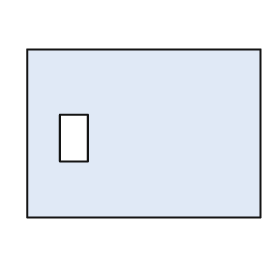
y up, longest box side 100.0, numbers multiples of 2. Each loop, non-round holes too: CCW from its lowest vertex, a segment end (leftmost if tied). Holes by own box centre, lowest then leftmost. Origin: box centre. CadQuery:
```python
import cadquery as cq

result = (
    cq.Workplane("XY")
    .moveTo(-50.0, -36.0)
    .lineTo(50.0, -36.0)
    .lineTo(50.0, 36.0)
    .lineTo(-50.0, 36.0)
    .close()
    .moveTo(-36.0, -12.0)
    .lineTo(-24.0, -12.0)
    .lineTo(-24.0, 8.0)
    .lineTo(-36.0, 8.0)
    .close()
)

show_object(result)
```